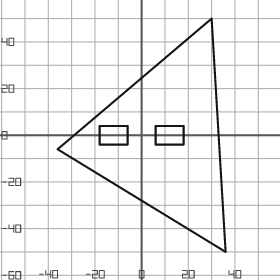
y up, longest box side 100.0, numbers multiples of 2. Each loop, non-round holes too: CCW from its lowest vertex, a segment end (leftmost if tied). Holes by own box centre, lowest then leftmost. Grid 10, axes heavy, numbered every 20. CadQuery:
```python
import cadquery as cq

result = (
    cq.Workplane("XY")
    .moveTo(36.0, -50.0)
    .lineTo(30.0, 50.0)
    .lineTo(-36.0, -6.0)
    .close()
    .moveTo(-18.0, -4.0)
    .lineTo(-6.0, -4.0)
    .lineTo(-6.0, 4.0)
    .lineTo(-18.0, 4.0)
    .close()
    .moveTo(6.0, -4.0)
    .lineTo(18.0, -4.0)
    .lineTo(18.0, 4.0)
    .lineTo(6.0, 4.0)
    .close()
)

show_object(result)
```